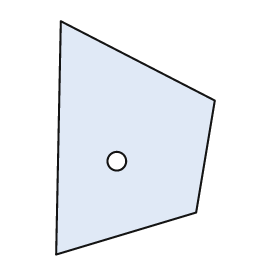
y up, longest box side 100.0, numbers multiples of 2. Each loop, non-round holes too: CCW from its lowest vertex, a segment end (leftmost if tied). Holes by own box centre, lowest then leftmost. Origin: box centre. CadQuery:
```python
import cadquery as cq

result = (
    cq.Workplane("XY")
    .moveTo(-34.0, -50.0)
    .lineTo(26.0, -32.0)
    .lineTo(34.0, 16.0)
    .lineTo(-32.0, 50.0)
    .close()
    .moveTo(-8.0, -10.0)
    .circle(4.0)
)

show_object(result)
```